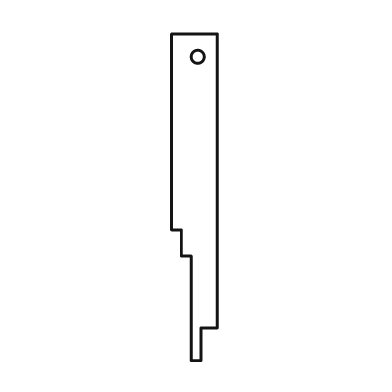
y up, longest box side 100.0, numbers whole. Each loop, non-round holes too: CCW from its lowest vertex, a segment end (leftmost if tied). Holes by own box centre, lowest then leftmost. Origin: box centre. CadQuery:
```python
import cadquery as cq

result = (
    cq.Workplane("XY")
    .moveTo(-1.0, -50.0)
    .lineTo(2.0, -50.0)
    .lineTo(2.0, -40.0)
    .lineTo(7.0, -40.0)
    .lineTo(7.0, 50.0)
    .lineTo(-7.0, 50.0)
    .lineTo(-7.0, -10.0)
    .lineTo(-4.0, -10.0)
    .lineTo(-4.0, -18.0)
    .lineTo(-1.0, -18.0)
    .close()
    .moveTo(1.0, 43.0)
    .circle(2.0)
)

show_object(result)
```